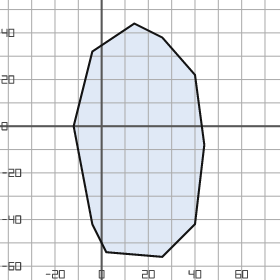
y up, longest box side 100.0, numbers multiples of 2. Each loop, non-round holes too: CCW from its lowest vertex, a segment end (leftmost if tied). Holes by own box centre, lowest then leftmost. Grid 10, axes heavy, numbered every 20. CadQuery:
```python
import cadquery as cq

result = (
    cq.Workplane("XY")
    .moveTo(26.0, -56.0)
    .lineTo(40.0, -42.0)
    .lineTo(44.0, -8.0)
    .lineTo(40.0, 22.0)
    .lineTo(26.0, 38.0)
    .lineTo(14.0, 44.0)
    .lineTo(-4.0, 32.0)
    .lineTo(-12.0, 0.0)
    .lineTo(-4.0, -42.0)
    .lineTo(2.0, -54.0)
    .close()
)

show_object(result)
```